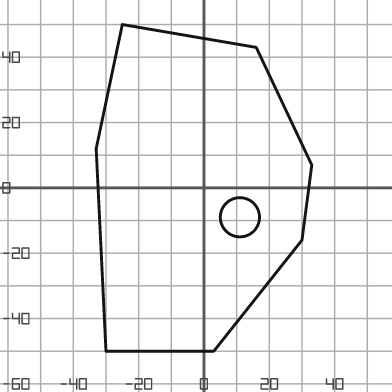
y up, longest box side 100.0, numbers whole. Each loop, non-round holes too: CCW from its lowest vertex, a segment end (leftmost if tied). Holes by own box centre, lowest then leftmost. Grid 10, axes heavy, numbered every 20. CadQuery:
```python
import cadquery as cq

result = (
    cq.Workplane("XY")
    .moveTo(-30.0, -50.0)
    .lineTo(3.0, -50.0)
    .lineTo(30.0, -16.0)
    .lineTo(33.0, 7.0)
    .lineTo(16.0, 43.0)
    .lineTo(-25.0, 50.0)
    .lineTo(-33.0, 12.0)
    .close()
    .moveTo(11.0, -9.0)
    .circle(6.0)
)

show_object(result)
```